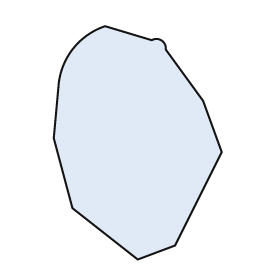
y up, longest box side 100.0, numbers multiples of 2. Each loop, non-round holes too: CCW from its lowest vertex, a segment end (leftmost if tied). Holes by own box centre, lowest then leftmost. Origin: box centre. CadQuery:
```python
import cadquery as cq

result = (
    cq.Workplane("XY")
    .moveTo(0.0, -50.0)
    .lineTo(16.0, -44.0)
    .lineTo(36.0, -4.0)
    .lineTo(28.0, 18.0)
    .lineTo(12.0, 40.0)
    .threePointArc((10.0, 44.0), (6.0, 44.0))
    .lineTo(-14.0, 50.0)
    .threePointArc((-28.0, 40.0), (-34.0, 24.0))
    .lineTo(-36.0, 2.0)
    .lineTo(-28.0, -28.0)
    .close()
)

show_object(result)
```